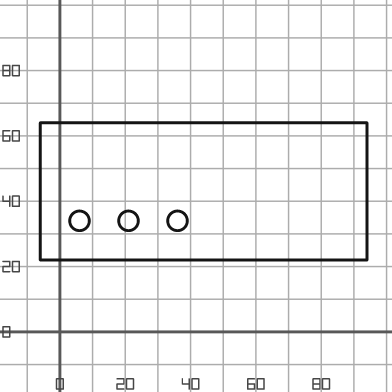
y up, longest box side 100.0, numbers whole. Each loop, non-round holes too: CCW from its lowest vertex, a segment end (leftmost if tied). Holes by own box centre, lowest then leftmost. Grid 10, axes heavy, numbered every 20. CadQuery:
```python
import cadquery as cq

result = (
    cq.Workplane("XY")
    .moveTo(-6.0, 22.0)
    .lineTo(94.0, 22.0)
    .lineTo(94.0, 64.0)
    .lineTo(-6.0, 64.0)
    .close()
    .moveTo(6.0, 34.0)
    .circle(3.0)
    .moveTo(21.0, 34.0)
    .circle(3.0)
    .moveTo(36.0, 34.0)
    .circle(3.0)
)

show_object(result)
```